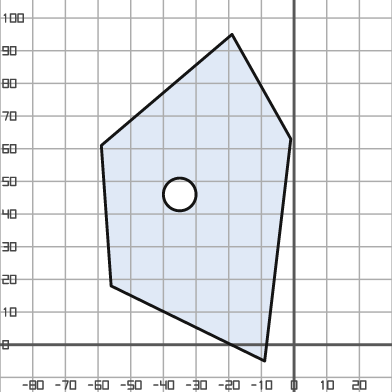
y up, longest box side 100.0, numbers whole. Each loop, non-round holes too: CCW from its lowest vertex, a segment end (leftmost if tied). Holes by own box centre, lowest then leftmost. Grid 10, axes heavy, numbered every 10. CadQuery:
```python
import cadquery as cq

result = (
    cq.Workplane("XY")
    .moveTo(-9.0, -5.0)
    .lineTo(-1.0, 63.0)
    .lineTo(-19.0, 95.0)
    .lineTo(-59.0, 61.0)
    .lineTo(-56.0, 18.0)
    .close()
    .moveTo(-35.0, 46.0)
    .circle(5.0)
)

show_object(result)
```